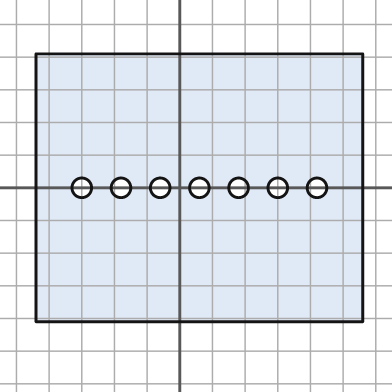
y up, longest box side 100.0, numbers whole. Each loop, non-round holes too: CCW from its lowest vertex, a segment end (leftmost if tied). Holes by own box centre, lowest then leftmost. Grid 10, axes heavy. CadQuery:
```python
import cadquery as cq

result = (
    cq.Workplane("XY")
    .moveTo(-44.0, -41.0)
    .lineTo(56.0, -41.0)
    .lineTo(56.0, 41.0)
    .lineTo(-44.0, 41.0)
    .close()
    .moveTo(-30.0, 0.0)
    .circle(3.0)
    .moveTo(-18.0, 0.0)
    .circle(3.0)
    .moveTo(-6.0, 0.0)
    .circle(3.0)
    .moveTo(6.0, 0.0)
    .circle(3.0)
    .moveTo(18.0, 0.0)
    .circle(3.0)
    .moveTo(30.0, 0.0)
    .circle(3.0)
    .moveTo(42.0, 0.0)
    .circle(3.0)
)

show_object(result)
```